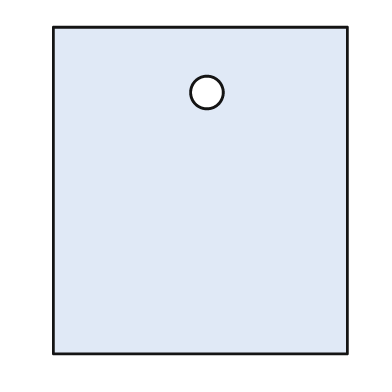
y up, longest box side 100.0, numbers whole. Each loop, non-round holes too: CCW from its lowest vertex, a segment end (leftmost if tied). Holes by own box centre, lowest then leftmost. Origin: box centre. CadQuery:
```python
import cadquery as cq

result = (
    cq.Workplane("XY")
    .moveTo(-45.0, -50.0)
    .lineTo(45.0, -50.0)
    .lineTo(45.0, 50.0)
    .lineTo(-45.0, 50.0)
    .close()
    .moveTo(2.0, 30.0)
    .circle(5.0)
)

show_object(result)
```